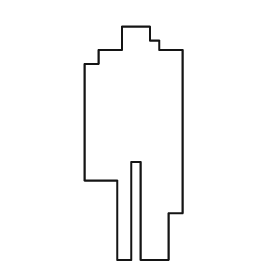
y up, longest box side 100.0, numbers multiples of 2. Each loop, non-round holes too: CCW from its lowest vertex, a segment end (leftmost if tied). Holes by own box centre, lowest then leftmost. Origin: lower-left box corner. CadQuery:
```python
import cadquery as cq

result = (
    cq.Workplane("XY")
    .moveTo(14.0, 0.0)
    .lineTo(20.0, 0.0)
    .lineTo(20.0, 42.0)
    .lineTo(24.0, 42.0)
    .lineTo(24.0, 0.0)
    .lineTo(36.0, 0.0)
    .lineTo(36.0, 20.0)
    .lineTo(42.0, 20.0)
    .lineTo(42.0, 90.0)
    .lineTo(32.0, 90.0)
    .lineTo(32.0, 94.0)
    .lineTo(28.0, 94.0)
    .lineTo(28.0, 100.0)
    .lineTo(16.0, 100.0)
    .lineTo(16.0, 90.0)
    .lineTo(6.0, 90.0)
    .lineTo(6.0, 84.0)
    .lineTo(0.0, 84.0)
    .lineTo(0.0, 34.0)
    .lineTo(14.0, 34.0)
    .close()
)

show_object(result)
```